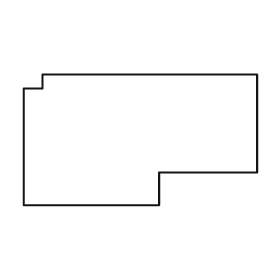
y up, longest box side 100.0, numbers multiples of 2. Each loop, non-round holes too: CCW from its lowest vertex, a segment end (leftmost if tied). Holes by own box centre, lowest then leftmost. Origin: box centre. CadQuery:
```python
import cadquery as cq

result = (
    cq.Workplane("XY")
    .moveTo(-50.0, -28.0)
    .lineTo(8.0, -28.0)
    .lineTo(8.0, -14.0)
    .lineTo(50.0, -14.0)
    .lineTo(50.0, 28.0)
    .lineTo(-42.0, 28.0)
    .lineTo(-42.0, 22.0)
    .lineTo(-50.0, 22.0)
    .close()
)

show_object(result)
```